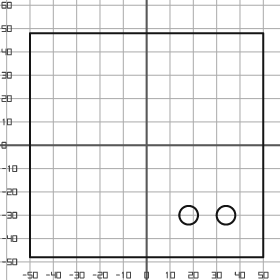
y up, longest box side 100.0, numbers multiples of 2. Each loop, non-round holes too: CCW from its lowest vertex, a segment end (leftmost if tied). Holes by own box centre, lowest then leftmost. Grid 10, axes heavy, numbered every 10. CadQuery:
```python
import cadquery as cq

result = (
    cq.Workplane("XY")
    .moveTo(-50.0, -48.0)
    .lineTo(50.0, -48.0)
    .lineTo(50.0, 48.0)
    .lineTo(-50.0, 48.0)
    .close()
    .moveTo(18.0, -30.0)
    .circle(4.0)
    .moveTo(34.0, -30.0)
    .circle(4.0)
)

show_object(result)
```